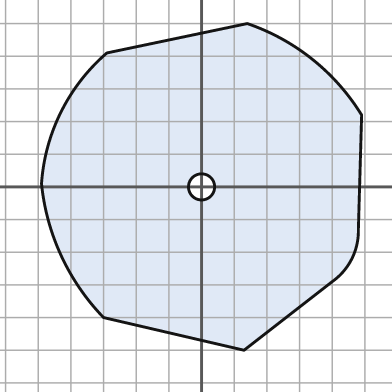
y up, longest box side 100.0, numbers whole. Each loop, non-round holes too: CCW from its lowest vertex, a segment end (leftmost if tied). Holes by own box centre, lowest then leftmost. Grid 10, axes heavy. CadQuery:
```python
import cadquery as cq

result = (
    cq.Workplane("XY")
    .moveTo(13.0, -50.0)
    .lineTo(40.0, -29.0)
    .threePointArc((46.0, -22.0), (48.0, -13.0))
    .lineTo(49.0, 22.0)
    .threePointArc((34.0, 39.0), (14.0, 50.0))
    .lineTo(-29.0, 41.0)
    .threePointArc((-43.0, 23.0), (-49.0, 1.0))
    .threePointArc((-43.0, -21.0), (-30.0, -40.0))
    .close()
    .moveTo(0.0, 0.0)
    .circle(4.0)
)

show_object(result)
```